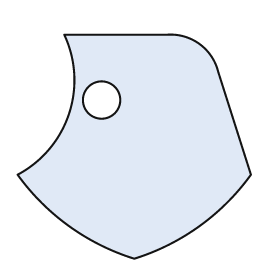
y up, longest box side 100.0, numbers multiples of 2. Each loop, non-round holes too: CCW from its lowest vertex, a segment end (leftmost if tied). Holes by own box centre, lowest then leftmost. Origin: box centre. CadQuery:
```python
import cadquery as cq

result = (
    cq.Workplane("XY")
    .moveTo(0.0, -48.0)
    .threePointArc((28.0, -34.0), (50.0, -12.0))
    .lineTo(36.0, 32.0)
    .threePointArc((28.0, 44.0), (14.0, 48.0))
    .lineTo(-30.0, 48.0)
    .threePointArc((-28.0, 14.0), (-50.0, -12.0))
    .threePointArc((-28.0, -34.0), (0.0, -48.0))
    .close()
    .moveTo(-14.0, 20.0)
    .circle(8.0)
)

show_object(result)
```